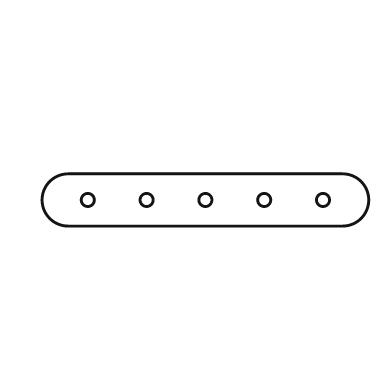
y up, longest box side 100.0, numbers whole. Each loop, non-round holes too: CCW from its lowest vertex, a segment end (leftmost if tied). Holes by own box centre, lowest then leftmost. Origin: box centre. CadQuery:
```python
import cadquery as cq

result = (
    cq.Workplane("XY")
    .moveTo(-42.0, -8.0)
    .lineTo(42.0, -8.0)
    .threePointArc((50.0, 0.0), (42.0, 8.0))
    .lineTo(-42.0, 8.0)
    .threePointArc((-50.0, 0.0), (-42.0, -8.0))
    .close()
    .moveTo(-36.0, 0.0)
    .circle(2.0)
    .moveTo(-18.0, 0.0)
    .circle(2.0)
    .moveTo(0.0, 0.0)
    .circle(2.0)
    .moveTo(18.0, 0.0)
    .circle(2.0)
    .moveTo(36.0, 0.0)
    .circle(2.0)
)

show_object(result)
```